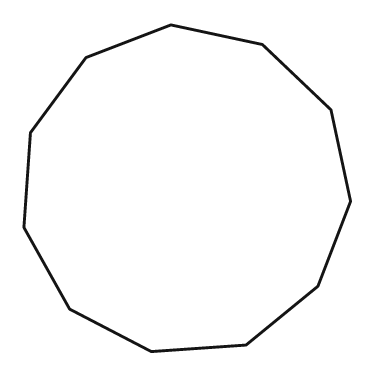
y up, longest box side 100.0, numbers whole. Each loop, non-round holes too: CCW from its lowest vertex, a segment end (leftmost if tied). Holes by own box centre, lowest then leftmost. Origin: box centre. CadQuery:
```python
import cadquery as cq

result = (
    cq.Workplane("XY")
    .moveTo(-11.0, -50.0)
    .lineTo(18.0, -48.0)
    .lineTo(40.0, -30.0)
    .lineTo(50.0, -4.0)
    .lineTo(44.0, 24.0)
    .lineTo(23.0, 44.0)
    .lineTo(-5.0, 50.0)
    .lineTo(-31.0, 40.0)
    .lineTo(-48.0, 17.0)
    .lineTo(-50.0, -12.0)
    .lineTo(-36.0, -37.0)
    .close()
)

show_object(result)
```